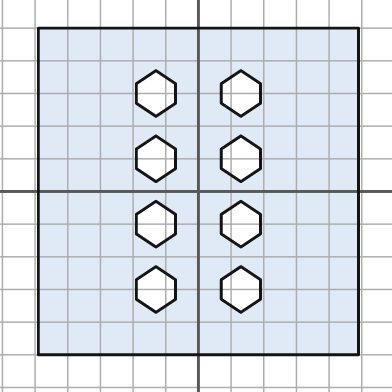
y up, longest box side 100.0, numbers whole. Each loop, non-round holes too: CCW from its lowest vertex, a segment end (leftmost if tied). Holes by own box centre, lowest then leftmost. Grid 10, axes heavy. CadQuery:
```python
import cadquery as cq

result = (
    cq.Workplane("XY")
    .moveTo(-49.0, -50.0)
    .lineTo(49.0, -50.0)
    .lineTo(49.0, 50.0)
    .lineTo(-49.0, 50.0)
    .close()
    .moveTo(-13.0, -37.0)
    .lineTo(-7.0, -33.0)
    .lineTo(-7.0, -27.0)
    .lineTo(-13.0, -23.0)
    .lineTo(-19.0, -27.0)
    .lineTo(-19.0, -33.0)
    .close()
    .moveTo(13.0, -37.0)
    .lineTo(19.0, -33.0)
    .lineTo(19.0, -27.0)
    .lineTo(13.0, -23.0)
    .lineTo(7.0, -27.0)
    .lineTo(7.0, -33.0)
    .close()
    .moveTo(-13.0, -17.0)
    .lineTo(-7.0, -13.0)
    .lineTo(-7.0, -7.0)
    .lineTo(-13.0, -3.0)
    .lineTo(-19.0, -7.0)
    .lineTo(-19.0, -13.0)
    .close()
    .moveTo(13.0, -17.0)
    .lineTo(19.0, -13.0)
    .lineTo(19.0, -7.0)
    .lineTo(13.0, -3.0)
    .lineTo(7.0, -7.0)
    .lineTo(7.0, -13.0)
    .close()
    .moveTo(-13.0, 3.0)
    .lineTo(-7.0, 7.0)
    .lineTo(-7.0, 13.0)
    .lineTo(-13.0, 17.0)
    .lineTo(-19.0, 13.0)
    .lineTo(-19.0, 7.0)
    .close()
    .moveTo(13.0, 3.0)
    .lineTo(19.0, 7.0)
    .lineTo(19.0, 13.0)
    .lineTo(13.0, 17.0)
    .lineTo(7.0, 13.0)
    .lineTo(7.0, 7.0)
    .close()
    .moveTo(-13.0, 23.0)
    .lineTo(-7.0, 27.0)
    .lineTo(-7.0, 33.0)
    .lineTo(-13.0, 37.0)
    .lineTo(-19.0, 33.0)
    .lineTo(-19.0, 27.0)
    .close()
    .moveTo(13.0, 23.0)
    .lineTo(19.0, 27.0)
    .lineTo(19.0, 33.0)
    .lineTo(13.0, 37.0)
    .lineTo(7.0, 33.0)
    .lineTo(7.0, 27.0)
    .close()
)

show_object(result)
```